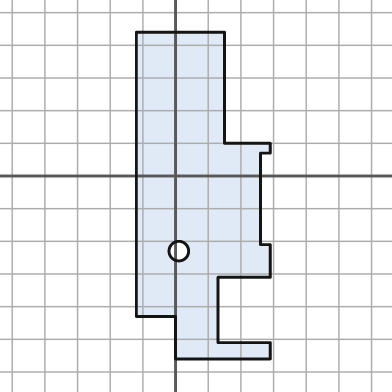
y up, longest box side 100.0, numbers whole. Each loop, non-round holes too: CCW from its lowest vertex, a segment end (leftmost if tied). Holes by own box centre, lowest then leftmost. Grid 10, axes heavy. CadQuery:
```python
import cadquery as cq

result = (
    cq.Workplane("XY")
    .moveTo(0.0, -56.0)
    .lineTo(29.0, -56.0)
    .lineTo(29.0, -51.0)
    .lineTo(13.0, -51.0)
    .lineTo(13.0, -31.0)
    .lineTo(29.0, -31.0)
    .lineTo(29.0, -21.0)
    .lineTo(26.0, -21.0)
    .lineTo(26.0, 7.0)
    .lineTo(29.0, 7.0)
    .lineTo(29.0, 10.0)
    .lineTo(15.0, 10.0)
    .lineTo(15.0, 44.0)
    .lineTo(-12.0, 44.0)
    .lineTo(-12.0, -43.0)
    .lineTo(0.0, -43.0)
    .close()
    .moveTo(1.0, -23.0)
    .circle(3.0)
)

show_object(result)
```